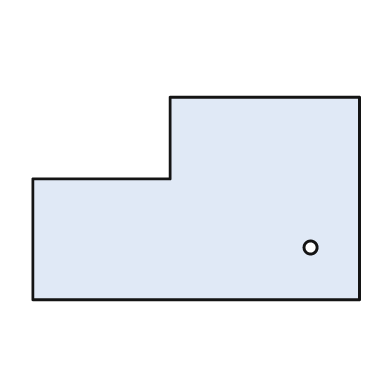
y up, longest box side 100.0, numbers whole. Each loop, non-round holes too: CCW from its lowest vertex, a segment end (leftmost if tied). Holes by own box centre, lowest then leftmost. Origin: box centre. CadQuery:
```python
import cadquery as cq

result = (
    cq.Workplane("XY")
    .moveTo(-50.0, -31.0)
    .lineTo(50.0, -31.0)
    .lineTo(50.0, 31.0)
    .lineTo(-8.0, 31.0)
    .lineTo(-8.0, 6.0)
    .lineTo(-50.0, 6.0)
    .close()
    .moveTo(35.0, -15.0)
    .circle(2.0)
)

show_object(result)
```